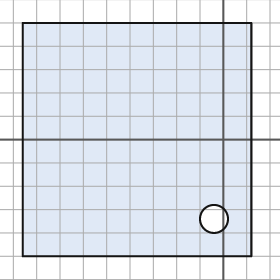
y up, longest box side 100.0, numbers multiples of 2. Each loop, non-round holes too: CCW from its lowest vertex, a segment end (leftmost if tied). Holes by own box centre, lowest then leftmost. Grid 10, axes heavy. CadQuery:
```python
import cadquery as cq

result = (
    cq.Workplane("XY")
    .moveTo(-86.0, -50.0)
    .lineTo(12.0, -50.0)
    .lineTo(12.0, 50.0)
    .lineTo(-86.0, 50.0)
    .close()
    .moveTo(-4.0, -34.0)
    .circle(6.0)
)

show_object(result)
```